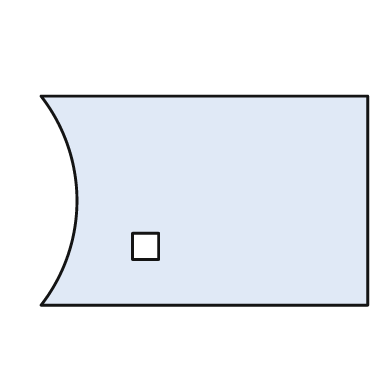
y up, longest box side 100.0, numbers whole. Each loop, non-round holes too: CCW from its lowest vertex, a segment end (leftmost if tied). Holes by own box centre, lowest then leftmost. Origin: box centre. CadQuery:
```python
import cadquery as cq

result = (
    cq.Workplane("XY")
    .moveTo(-50.0, -32.0)
    .lineTo(50.0, -32.0)
    .lineTo(50.0, 32.0)
    .lineTo(-50.0, 32.0)
    .threePointArc((-39.0, 0.0), (-50.0, -32.0))
    .close()
    .moveTo(-22.0, -18.0)
    .lineTo(-14.0, -18.0)
    .lineTo(-14.0, -10.0)
    .lineTo(-22.0, -10.0)
    .close()
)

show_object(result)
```